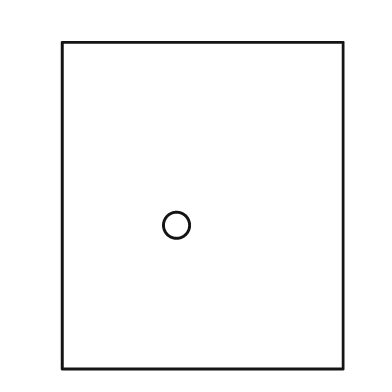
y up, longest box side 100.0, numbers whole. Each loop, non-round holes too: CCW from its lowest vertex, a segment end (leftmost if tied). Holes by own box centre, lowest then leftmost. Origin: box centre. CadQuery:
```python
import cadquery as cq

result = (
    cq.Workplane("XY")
    .moveTo(-43.0, -50.0)
    .lineTo(43.0, -50.0)
    .lineTo(43.0, 50.0)
    .lineTo(-43.0, 50.0)
    .close()
    .moveTo(-8.0, -6.0)
    .circle(4.0)
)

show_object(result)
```